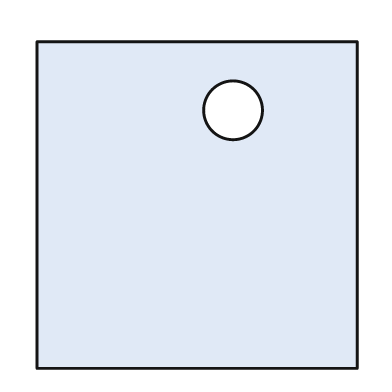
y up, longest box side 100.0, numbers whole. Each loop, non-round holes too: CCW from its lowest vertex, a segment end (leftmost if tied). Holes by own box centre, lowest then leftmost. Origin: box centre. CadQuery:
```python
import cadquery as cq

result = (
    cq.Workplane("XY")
    .moveTo(-49.0, -50.0)
    .lineTo(49.0, -50.0)
    .lineTo(49.0, 50.0)
    .lineTo(-49.0, 50.0)
    .close()
    .moveTo(11.0, 29.0)
    .circle(9.0)
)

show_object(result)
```